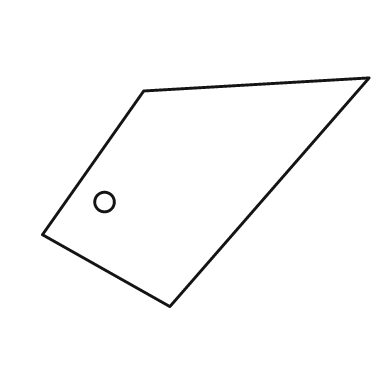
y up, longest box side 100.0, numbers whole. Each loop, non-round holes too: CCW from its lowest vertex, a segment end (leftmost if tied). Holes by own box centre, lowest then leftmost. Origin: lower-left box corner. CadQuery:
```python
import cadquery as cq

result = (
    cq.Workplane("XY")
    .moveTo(39.0, 0.0)
    .lineTo(100.0, 70.0)
    .lineTo(31.0, 66.0)
    .lineTo(0.0, 22.0)
    .close()
    .moveTo(19.0, 32.0)
    .circle(3.0)
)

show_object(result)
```